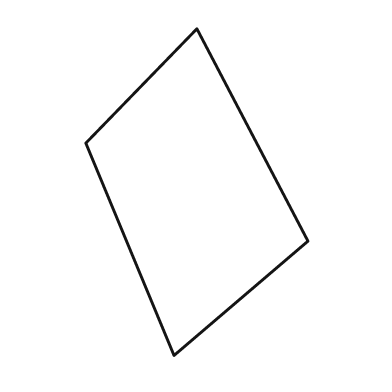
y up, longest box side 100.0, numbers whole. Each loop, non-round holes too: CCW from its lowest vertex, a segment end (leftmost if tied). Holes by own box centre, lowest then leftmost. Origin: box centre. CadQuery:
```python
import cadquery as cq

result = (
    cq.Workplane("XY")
    .moveTo(-7.0, -50.0)
    .lineTo(34.0, -15.0)
    .lineTo(0.0, 50.0)
    .lineTo(-34.0, 15.0)
    .close()
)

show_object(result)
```